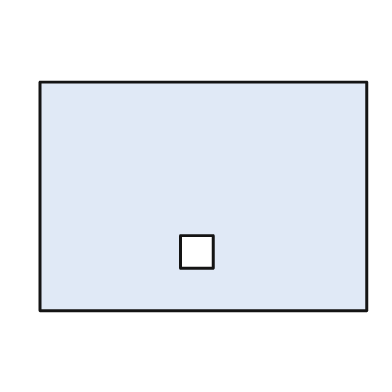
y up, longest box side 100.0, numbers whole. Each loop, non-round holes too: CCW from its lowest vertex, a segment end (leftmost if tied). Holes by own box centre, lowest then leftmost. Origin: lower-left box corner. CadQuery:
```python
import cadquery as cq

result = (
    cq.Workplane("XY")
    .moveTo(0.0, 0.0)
    .lineTo(100.0, 0.0)
    .lineTo(100.0, 70.0)
    .lineTo(0.0, 70.0)
    .close()
    .moveTo(43.0, 13.0)
    .lineTo(53.0, 13.0)
    .lineTo(53.0, 23.0)
    .lineTo(43.0, 23.0)
    .close()
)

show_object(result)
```